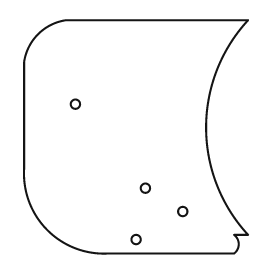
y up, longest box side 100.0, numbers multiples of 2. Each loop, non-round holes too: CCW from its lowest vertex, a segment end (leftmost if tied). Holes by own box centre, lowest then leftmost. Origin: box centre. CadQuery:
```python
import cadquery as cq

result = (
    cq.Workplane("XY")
    .moveTo(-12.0, -50.0)
    .lineTo(42.0, -50.0)
    .threePointArc((44.0, -46.0), (42.0, -42.0))
    .lineTo(48.0, -42.0)
    .threePointArc((30.0, 4.0), (48.0, 50.0))
    .lineTo(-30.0, 50.0)
    .threePointArc((-42.0, 44.0), (-48.0, 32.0))
    .lineTo(-48.0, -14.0)
    .threePointArc((-38.0, -40.0), (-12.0, -50.0))
    .close()
    .moveTo(0.0, -44.0)
    .circle(2.0)
    .moveTo(20.0, -32.0)
    .circle(2.0)
    .moveTo(4.0, -22.0)
    .circle(2.0)
    .moveTo(-26.0, 14.0)
    .circle(2.0)
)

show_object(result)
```